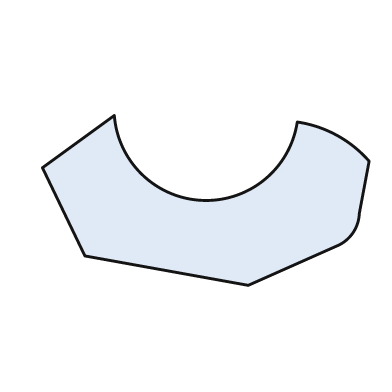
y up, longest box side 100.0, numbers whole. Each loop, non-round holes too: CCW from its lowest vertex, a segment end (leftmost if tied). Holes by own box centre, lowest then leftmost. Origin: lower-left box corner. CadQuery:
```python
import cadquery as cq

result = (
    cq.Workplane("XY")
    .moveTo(63.0, 0.0)
    .lineTo(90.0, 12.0)
    .threePointArc((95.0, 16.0), (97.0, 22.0))
    .lineTo(100.0, 38.0)
    .threePointArc((90.0, 46.0), (78.0, 50.0))
    .threePointArc((49.0, 26.0), (22.0, 52.0))
    .lineTo(0.0, 36.0)
    .lineTo(13.0, 9.0)
    .close()
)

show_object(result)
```